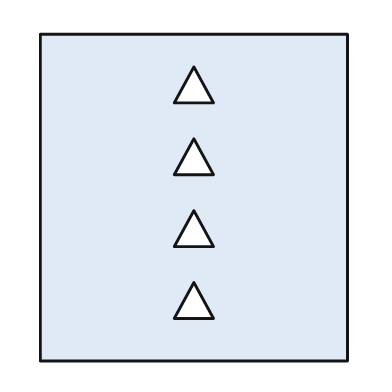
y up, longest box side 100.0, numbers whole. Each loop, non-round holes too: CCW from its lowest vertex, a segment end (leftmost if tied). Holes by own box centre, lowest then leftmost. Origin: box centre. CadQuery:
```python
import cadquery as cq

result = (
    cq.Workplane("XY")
    .moveTo(-47.0, -50.0)
    .lineTo(47.0, -50.0)
    .lineTo(47.0, 50.0)
    .lineTo(-47.0, 50.0)
    .close()
    .moveTo(-6.0, -37.0)
    .lineTo(6.0, -37.0)
    .lineTo(0.0, -26.0)
    .close()
    .moveTo(-6.0, -15.0)
    .lineTo(6.0, -15.0)
    .lineTo(0.0, -4.0)
    .close()
    .moveTo(-6.0, 7.0)
    .lineTo(6.0, 7.0)
    .lineTo(0.0, 18.0)
    .close()
    .moveTo(-6.0, 29.0)
    .lineTo(6.0, 29.0)
    .lineTo(0.0, 40.0)
    .close()
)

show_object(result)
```